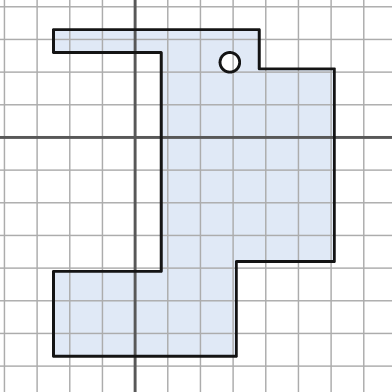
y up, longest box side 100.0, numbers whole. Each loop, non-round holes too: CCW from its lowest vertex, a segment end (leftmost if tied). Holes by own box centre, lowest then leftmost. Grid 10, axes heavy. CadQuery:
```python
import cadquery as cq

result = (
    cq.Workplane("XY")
    .moveTo(-25.0, -67.0)
    .lineTo(31.0, -67.0)
    .lineTo(31.0, -38.0)
    .lineTo(61.0, -38.0)
    .lineTo(61.0, 21.0)
    .lineTo(38.0, 21.0)
    .lineTo(38.0, 33.0)
    .lineTo(-25.0, 33.0)
    .lineTo(-25.0, 26.0)
    .lineTo(8.0, 26.0)
    .lineTo(8.0, -41.0)
    .lineTo(-25.0, -41.0)
    .close()
    .moveTo(29.0, 23.0)
    .circle(3.0)
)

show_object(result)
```